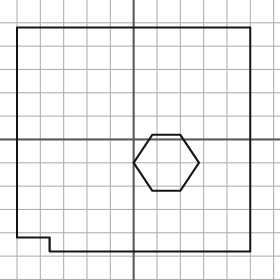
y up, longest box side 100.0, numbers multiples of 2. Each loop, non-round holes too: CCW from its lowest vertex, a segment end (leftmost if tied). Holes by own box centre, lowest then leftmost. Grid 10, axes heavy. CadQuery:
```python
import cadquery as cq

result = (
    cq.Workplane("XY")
    .moveTo(-36.0, -48.0)
    .lineTo(50.0, -48.0)
    .lineTo(50.0, 48.0)
    .lineTo(-50.0, 48.0)
    .lineTo(-50.0, -42.0)
    .lineTo(-36.0, -42.0)
    .close()
    .moveTo(8.0, -22.0)
    .lineTo(20.0, -22.0)
    .lineTo(28.0, -10.0)
    .lineTo(20.0, 2.0)
    .lineTo(8.0, 2.0)
    .lineTo(0.0, -10.0)
    .close()
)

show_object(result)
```